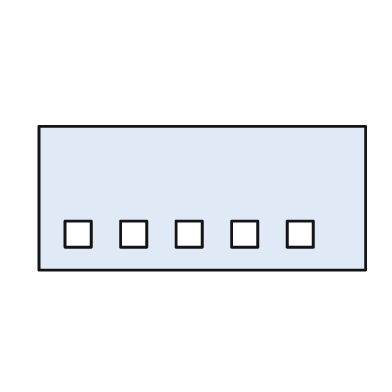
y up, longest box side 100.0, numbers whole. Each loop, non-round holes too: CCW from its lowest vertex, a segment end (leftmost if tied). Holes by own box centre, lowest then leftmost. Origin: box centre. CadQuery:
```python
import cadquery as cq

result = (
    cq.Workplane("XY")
    .moveTo(-50.0, -22.0)
    .lineTo(50.0, -22.0)
    .lineTo(50.0, 22.0)
    .lineTo(-50.0, 22.0)
    .close()
    .moveTo(-42.0, -15.0)
    .lineTo(-34.0, -15.0)
    .lineTo(-34.0, -7.0)
    .lineTo(-42.0, -7.0)
    .close()
    .moveTo(-25.0, -15.0)
    .lineTo(-17.0, -15.0)
    .lineTo(-17.0, -7.0)
    .lineTo(-25.0, -7.0)
    .close()
    .moveTo(-8.0, -15.0)
    .lineTo(0.0, -15.0)
    .lineTo(0.0, -7.0)
    .lineTo(-8.0, -7.0)
    .close()
    .moveTo(9.0, -15.0)
    .lineTo(17.0, -15.0)
    .lineTo(17.0, -7.0)
    .lineTo(9.0, -7.0)
    .close()
    .moveTo(26.0, -15.0)
    .lineTo(34.0, -15.0)
    .lineTo(34.0, -7.0)
    .lineTo(26.0, -7.0)
    .close()
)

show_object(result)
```